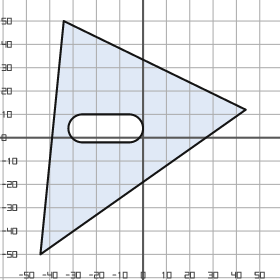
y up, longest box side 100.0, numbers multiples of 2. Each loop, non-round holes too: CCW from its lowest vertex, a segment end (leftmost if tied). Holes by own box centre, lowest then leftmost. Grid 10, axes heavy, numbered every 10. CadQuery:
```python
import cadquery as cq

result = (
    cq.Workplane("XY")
    .moveTo(-44.0, -50.0)
    .lineTo(44.0, 12.0)
    .lineTo(-34.0, 50.0)
    .close()
    .moveTo(-26.0, -2.0)
    .lineTo(-6.0, -2.0)
    .threePointArc((0.0, 4.0), (-6.0, 10.0))
    .lineTo(-26.0, 10.0)
    .threePointArc((-32.0, 4.0), (-26.0, -2.0))
    .close()
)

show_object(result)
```